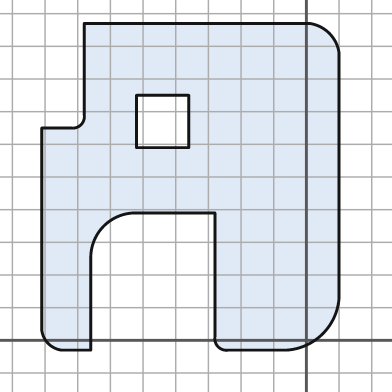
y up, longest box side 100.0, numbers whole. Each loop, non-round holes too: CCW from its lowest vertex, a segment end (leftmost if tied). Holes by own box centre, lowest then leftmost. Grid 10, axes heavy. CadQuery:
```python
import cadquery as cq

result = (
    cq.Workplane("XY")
    .moveTo(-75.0, -3.0)
    .lineTo(-66.0, -3.0)
    .lineTo(-66.0, 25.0)
    .threePointArc((-62.0, 35.0), (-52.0, 39.0))
    .lineTo(-28.0, 39.0)
    .lineTo(-28.0, 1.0)
    .threePointArc((-27.0, -2.0), (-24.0, -3.0))
    .lineTo(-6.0, -3.0)
    .threePointArc((5.0, 2.0), (10.0, 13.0))
    .lineTo(10.0, 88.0)
    .threePointArc((7.0, 94.0), (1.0, 97.0))
    .lineTo(-68.0, 97.0)
    .lineTo(-68.0, 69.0)
    .threePointArc((-69.0, 66.0), (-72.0, 65.0))
    .lineTo(-81.0, 65.0)
    .lineTo(-81.0, 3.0)
    .threePointArc((-79.0, -1.0), (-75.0, -3.0))
    .close()
    .moveTo(-52.0, 59.0)
    .lineTo(-36.0, 59.0)
    .lineTo(-36.0, 75.0)
    .lineTo(-52.0, 75.0)
    .close()
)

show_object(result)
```